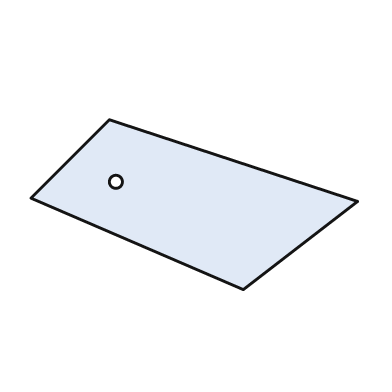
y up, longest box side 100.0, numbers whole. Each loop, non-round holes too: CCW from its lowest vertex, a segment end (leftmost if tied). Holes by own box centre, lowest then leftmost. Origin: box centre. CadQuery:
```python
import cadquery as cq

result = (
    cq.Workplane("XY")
    .moveTo(15.0, -26.0)
    .lineTo(50.0, 1.0)
    .lineTo(-26.0, 26.0)
    .lineTo(-50.0, 2.0)
    .close()
    .moveTo(-24.0, 7.0)
    .circle(2.0)
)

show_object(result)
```